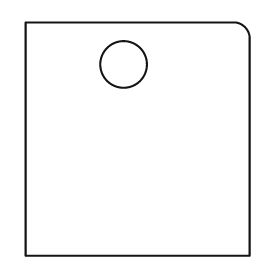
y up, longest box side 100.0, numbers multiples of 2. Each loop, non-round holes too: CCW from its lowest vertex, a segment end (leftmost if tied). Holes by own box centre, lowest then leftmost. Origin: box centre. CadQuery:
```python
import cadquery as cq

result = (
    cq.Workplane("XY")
    .moveTo(-48.0, -50.0)
    .lineTo(48.0, -50.0)
    .lineTo(48.0, 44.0)
    .threePointArc((46.0, 48.0), (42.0, 50.0))
    .lineTo(-48.0, 50.0)
    .close()
    .moveTo(-6.0, 32.0)
    .circle(10.0)
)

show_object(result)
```